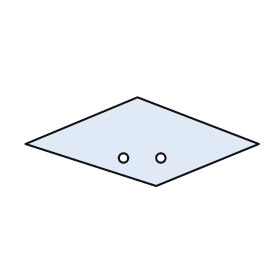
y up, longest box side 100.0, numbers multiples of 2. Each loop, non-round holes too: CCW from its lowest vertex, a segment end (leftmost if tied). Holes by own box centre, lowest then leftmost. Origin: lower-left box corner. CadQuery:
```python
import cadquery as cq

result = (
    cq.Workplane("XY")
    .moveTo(56.0, 0.0)
    .lineTo(100.0, 18.0)
    .lineTo(48.0, 38.0)
    .lineTo(0.0, 18.0)
    .close()
    .moveTo(42.0, 12.0)
    .circle(2.0)
    .moveTo(58.0, 12.0)
    .circle(2.0)
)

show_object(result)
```